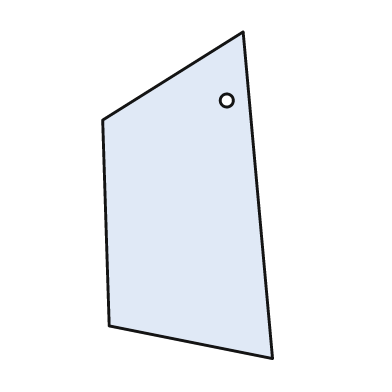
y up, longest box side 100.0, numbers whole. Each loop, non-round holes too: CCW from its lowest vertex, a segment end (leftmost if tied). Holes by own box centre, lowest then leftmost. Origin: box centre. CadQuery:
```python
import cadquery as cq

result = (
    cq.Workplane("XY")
    .moveTo(26.0, -50.0)
    .lineTo(17.0, 50.0)
    .lineTo(-26.0, 23.0)
    .lineTo(-24.0, -40.0)
    .close()
    .moveTo(12.0, 29.0)
    .circle(2.0)
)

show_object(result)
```